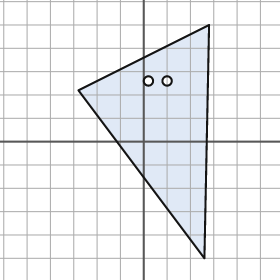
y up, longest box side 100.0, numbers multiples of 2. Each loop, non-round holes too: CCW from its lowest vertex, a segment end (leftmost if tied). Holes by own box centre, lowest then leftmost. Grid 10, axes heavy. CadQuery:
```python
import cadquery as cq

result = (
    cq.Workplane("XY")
    .moveTo(26.0, -50.0)
    .lineTo(28.0, 50.0)
    .lineTo(-28.0, 22.0)
    .close()
    .moveTo(2.0, 26.0)
    .circle(2.0)
    .moveTo(10.0, 26.0)
    .circle(2.0)
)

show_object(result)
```